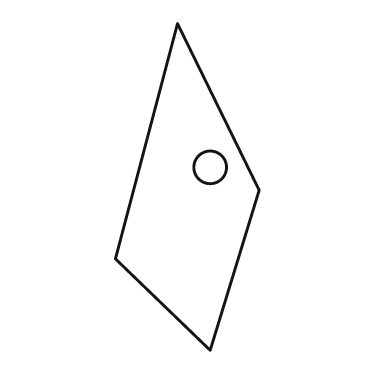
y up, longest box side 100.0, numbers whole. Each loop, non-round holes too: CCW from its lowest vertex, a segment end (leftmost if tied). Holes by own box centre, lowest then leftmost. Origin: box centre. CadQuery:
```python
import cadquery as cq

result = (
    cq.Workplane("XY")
    .moveTo(7.0, -50.0)
    .lineTo(22.0, -1.0)
    .lineTo(-3.0, 50.0)
    .lineTo(-22.0, -22.0)
    .close()
    .moveTo(7.0, 6.0)
    .circle(5.0)
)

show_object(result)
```